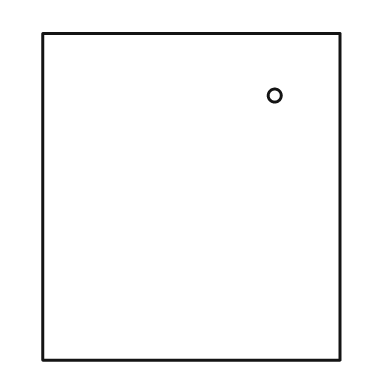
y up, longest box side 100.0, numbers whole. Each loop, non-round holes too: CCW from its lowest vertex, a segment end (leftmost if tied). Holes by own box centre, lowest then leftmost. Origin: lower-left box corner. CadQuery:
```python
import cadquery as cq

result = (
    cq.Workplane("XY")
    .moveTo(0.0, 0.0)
    .lineTo(91.0, 0.0)
    .lineTo(91.0, 100.0)
    .lineTo(0.0, 100.0)
    .close()
    .moveTo(71.0, 81.0)
    .circle(2.0)
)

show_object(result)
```